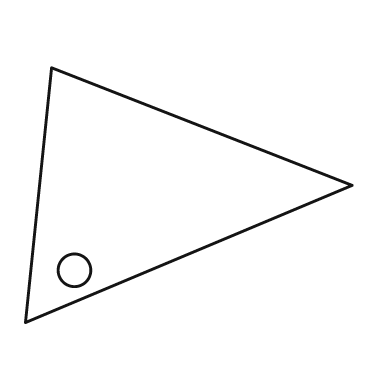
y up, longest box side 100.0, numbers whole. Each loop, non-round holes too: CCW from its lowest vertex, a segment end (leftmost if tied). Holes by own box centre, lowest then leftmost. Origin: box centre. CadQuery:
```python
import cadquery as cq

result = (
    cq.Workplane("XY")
    .moveTo(-50.0, -39.0)
    .lineTo(50.0, 3.0)
    .lineTo(-42.0, 39.0)
    .close()
    .moveTo(-35.0, -23.0)
    .circle(5.0)
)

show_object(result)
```